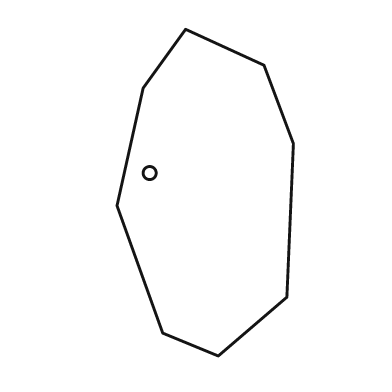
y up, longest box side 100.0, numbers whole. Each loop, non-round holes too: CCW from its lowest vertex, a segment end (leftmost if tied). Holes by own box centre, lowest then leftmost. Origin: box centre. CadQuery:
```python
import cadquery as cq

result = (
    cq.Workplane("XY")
    .moveTo(4.0, -50.0)
    .lineTo(25.0, -32.0)
    .lineTo(27.0, 15.0)
    .lineTo(18.0, 39.0)
    .lineTo(-6.0, 50.0)
    .lineTo(-19.0, 32.0)
    .lineTo(-27.0, -4.0)
    .lineTo(-13.0, -43.0)
    .close()
    .moveTo(-17.0, 6.0)
    .circle(2.0)
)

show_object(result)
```